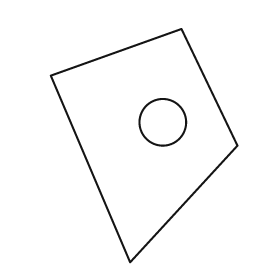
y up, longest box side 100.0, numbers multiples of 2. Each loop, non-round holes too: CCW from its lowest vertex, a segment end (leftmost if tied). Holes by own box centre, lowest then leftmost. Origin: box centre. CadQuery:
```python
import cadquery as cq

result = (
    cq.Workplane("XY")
    .moveTo(-6.0, -50.0)
    .lineTo(40.0, 0.0)
    .lineTo(16.0, 50.0)
    .lineTo(-40.0, 30.0)
    .close()
    .moveTo(8.0, 10.0)
    .circle(10.0)
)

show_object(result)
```